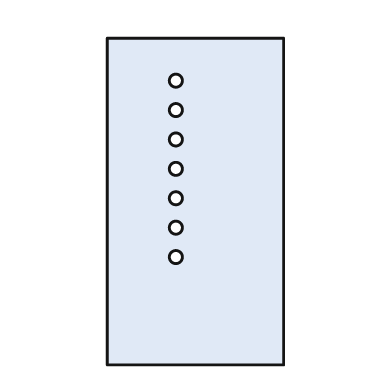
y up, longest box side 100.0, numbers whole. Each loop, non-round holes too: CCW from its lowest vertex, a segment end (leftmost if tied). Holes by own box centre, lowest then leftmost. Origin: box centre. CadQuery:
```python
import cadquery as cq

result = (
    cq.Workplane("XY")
    .moveTo(-27.0, -50.0)
    .lineTo(27.0, -50.0)
    .lineTo(27.0, 50.0)
    .lineTo(-27.0, 50.0)
    .close()
    .moveTo(-6.0, -17.0)
    .circle(2.0)
    .moveTo(-6.0, -8.0)
    .circle(2.0)
    .moveTo(-6.0, 1.0)
    .circle(2.0)
    .moveTo(-6.0, 10.0)
    .circle(2.0)
    .moveTo(-6.0, 19.0)
    .circle(2.0)
    .moveTo(-6.0, 28.0)
    .circle(2.0)
    .moveTo(-6.0, 37.0)
    .circle(2.0)
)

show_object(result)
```